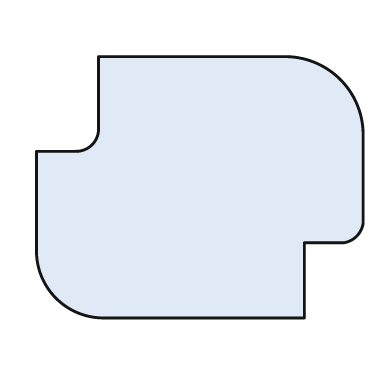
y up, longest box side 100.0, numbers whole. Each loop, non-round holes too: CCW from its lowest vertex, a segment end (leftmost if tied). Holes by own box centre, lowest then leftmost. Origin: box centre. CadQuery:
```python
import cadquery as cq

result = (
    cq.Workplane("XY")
    .moveTo(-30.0, -40.0)
    .lineTo(32.0, -40.0)
    .lineTo(32.0, -17.0)
    .lineTo(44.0, -17.0)
    .threePointArc((48.0, -15.0), (50.0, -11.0))
    .lineTo(50.0, 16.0)
    .threePointArc((43.0, 33.0), (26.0, 40.0))
    .lineTo(-31.0, 40.0)
    .lineTo(-31.0, 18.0)
    .threePointArc((-33.0, 13.0), (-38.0, 11.0))
    .lineTo(-50.0, 11.0)
    .lineTo(-50.0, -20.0)
    .threePointArc((-44.0, -34.0), (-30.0, -40.0))
    .close()
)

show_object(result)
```